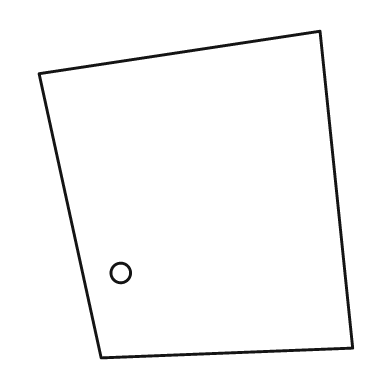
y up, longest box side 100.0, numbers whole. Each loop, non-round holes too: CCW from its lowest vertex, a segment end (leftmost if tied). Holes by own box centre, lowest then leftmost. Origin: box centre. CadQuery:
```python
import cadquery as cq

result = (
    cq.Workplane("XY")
    .moveTo(-29.0, -50.0)
    .lineTo(48.0, -47.0)
    .lineTo(38.0, 50.0)
    .lineTo(-48.0, 37.0)
    .close()
    .moveTo(-23.0, -24.0)
    .circle(3.0)
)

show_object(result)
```